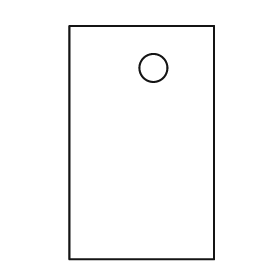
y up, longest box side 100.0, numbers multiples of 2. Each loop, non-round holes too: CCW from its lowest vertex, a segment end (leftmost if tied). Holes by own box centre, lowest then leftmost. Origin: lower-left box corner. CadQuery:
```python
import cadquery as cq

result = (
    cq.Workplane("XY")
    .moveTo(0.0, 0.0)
    .lineTo(62.0, 0.0)
    .lineTo(62.0, 100.0)
    .lineTo(0.0, 100.0)
    .close()
    .moveTo(36.0, 82.0)
    .circle(6.0)
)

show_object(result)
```